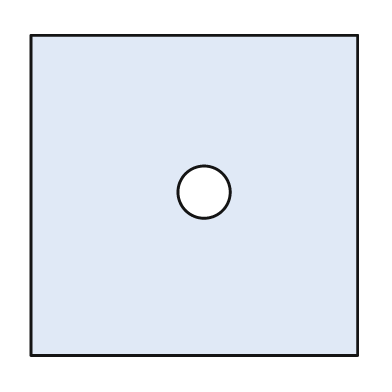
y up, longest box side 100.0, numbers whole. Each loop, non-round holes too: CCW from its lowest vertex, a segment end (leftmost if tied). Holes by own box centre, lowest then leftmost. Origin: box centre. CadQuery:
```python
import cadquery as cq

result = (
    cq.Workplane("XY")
    .moveTo(-50.0, -49.0)
    .lineTo(50.0, -49.0)
    .lineTo(50.0, 49.0)
    .lineTo(-50.0, 49.0)
    .close()
    .moveTo(3.0, 1.0)
    .circle(8.0)
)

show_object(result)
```